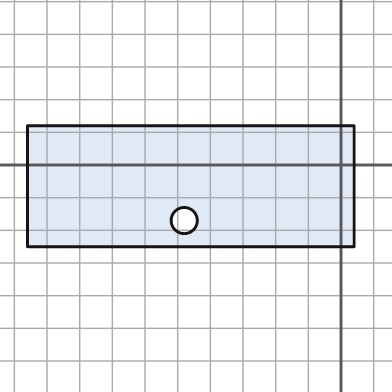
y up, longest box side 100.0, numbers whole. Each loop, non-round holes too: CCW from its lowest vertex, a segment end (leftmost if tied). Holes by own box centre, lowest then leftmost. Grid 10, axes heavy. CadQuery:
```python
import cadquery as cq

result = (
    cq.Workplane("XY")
    .moveTo(-96.0, -25.0)
    .lineTo(4.0, -25.0)
    .lineTo(4.0, 12.0)
    .lineTo(-96.0, 12.0)
    .close()
    .moveTo(-48.0, -17.0)
    .circle(4.0)
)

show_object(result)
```